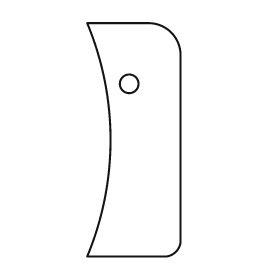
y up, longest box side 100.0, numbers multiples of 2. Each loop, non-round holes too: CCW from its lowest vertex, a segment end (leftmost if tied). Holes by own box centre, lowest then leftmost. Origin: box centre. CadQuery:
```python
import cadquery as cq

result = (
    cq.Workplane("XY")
    .moveTo(-20.0, -50.0)
    .lineTo(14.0, -50.0)
    .threePointArc((18.0, -48.0), (20.0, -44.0))
    .lineTo(20.0, 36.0)
    .threePointArc((16.0, 46.0), (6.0, 50.0))
    .lineTo(-20.0, 50.0)
    .threePointArc((-10.0, 0.0), (-20.0, -50.0))
    .close()
    .moveTo(-2.0, 24.0)
    .circle(4.0)
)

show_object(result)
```